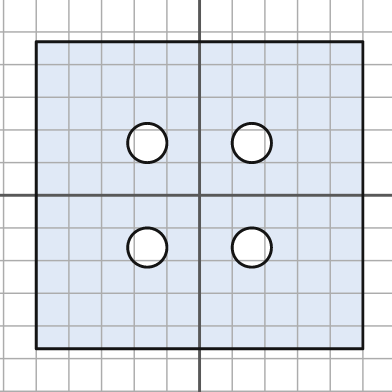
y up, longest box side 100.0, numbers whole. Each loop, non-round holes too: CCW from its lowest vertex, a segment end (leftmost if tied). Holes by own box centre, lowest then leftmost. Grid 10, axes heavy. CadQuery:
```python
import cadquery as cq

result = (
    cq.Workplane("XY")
    .moveTo(-50.0, -47.0)
    .lineTo(50.0, -47.0)
    .lineTo(50.0, 47.0)
    .lineTo(-50.0, 47.0)
    .close()
    .moveTo(-16.0, -16.0)
    .circle(6.0)
    .moveTo(16.0, -16.0)
    .circle(6.0)
    .moveTo(-16.0, 16.0)
    .circle(6.0)
    .moveTo(16.0, 16.0)
    .circle(6.0)
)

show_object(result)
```